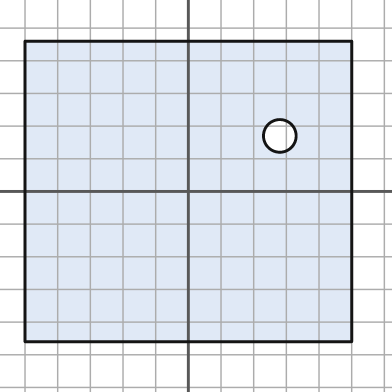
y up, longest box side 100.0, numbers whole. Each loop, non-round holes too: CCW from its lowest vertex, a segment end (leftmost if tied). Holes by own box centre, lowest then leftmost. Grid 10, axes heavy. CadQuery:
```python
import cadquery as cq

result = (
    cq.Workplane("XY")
    .moveTo(-50.0, -46.0)
    .lineTo(50.0, -46.0)
    .lineTo(50.0, 46.0)
    .lineTo(-50.0, 46.0)
    .close()
    .moveTo(28.0, 17.0)
    .circle(5.0)
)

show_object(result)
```